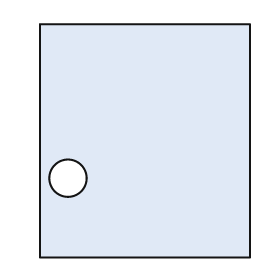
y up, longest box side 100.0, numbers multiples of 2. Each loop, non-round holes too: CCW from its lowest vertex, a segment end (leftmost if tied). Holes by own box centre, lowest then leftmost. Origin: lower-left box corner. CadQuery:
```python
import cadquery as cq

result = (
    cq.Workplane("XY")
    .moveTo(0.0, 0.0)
    .lineTo(90.0, 0.0)
    .lineTo(90.0, 100.0)
    .lineTo(0.0, 100.0)
    .close()
    .moveTo(12.0, 34.0)
    .circle(8.0)
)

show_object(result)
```